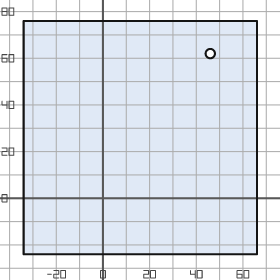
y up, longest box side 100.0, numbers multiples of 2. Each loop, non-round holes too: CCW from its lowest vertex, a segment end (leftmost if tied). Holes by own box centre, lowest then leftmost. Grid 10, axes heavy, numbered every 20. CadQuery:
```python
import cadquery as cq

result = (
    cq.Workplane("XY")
    .moveTo(-34.0, -24.0)
    .lineTo(66.0, -24.0)
    .lineTo(66.0, 76.0)
    .lineTo(-34.0, 76.0)
    .close()
    .moveTo(46.0, 62.0)
    .circle(2.0)
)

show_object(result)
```